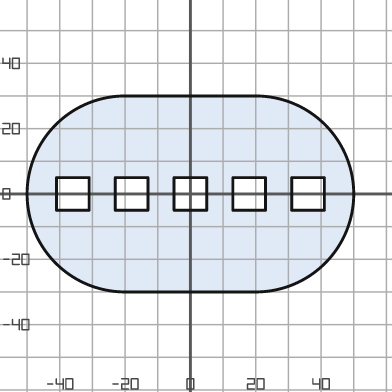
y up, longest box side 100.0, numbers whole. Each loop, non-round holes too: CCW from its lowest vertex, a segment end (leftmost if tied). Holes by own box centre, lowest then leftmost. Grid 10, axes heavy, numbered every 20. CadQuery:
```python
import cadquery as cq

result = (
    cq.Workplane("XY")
    .moveTo(-20.0, -30.0)
    .lineTo(20.0, -30.0)
    .threePointArc((50.0, 0.0), (20.0, 30.0))
    .lineTo(-20.0, 30.0)
    .threePointArc((-50.0, 0.0), (-20.0, -30.0))
    .close()
    .moveTo(-41.0, -5.0)
    .lineTo(-31.0, -5.0)
    .lineTo(-31.0, 5.0)
    .lineTo(-41.0, 5.0)
    .close()
    .moveTo(-23.0, -5.0)
    .lineTo(-13.0, -5.0)
    .lineTo(-13.0, 5.0)
    .lineTo(-23.0, 5.0)
    .close()
    .moveTo(-5.0, -5.0)
    .lineTo(5.0, -5.0)
    .lineTo(5.0, 5.0)
    .lineTo(-5.0, 5.0)
    .close()
    .moveTo(13.0, -5.0)
    .lineTo(23.0, -5.0)
    .lineTo(23.0, 5.0)
    .lineTo(13.0, 5.0)
    .close()
    .moveTo(31.0, -5.0)
    .lineTo(41.0, -5.0)
    .lineTo(41.0, 5.0)
    .lineTo(31.0, 5.0)
    .close()
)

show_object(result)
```